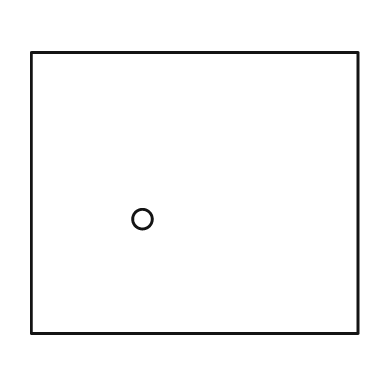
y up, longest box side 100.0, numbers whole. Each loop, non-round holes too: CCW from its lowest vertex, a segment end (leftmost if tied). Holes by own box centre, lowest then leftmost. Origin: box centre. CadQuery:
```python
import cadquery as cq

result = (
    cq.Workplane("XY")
    .moveTo(-50.0, -43.0)
    .lineTo(50.0, -43.0)
    .lineTo(50.0, 43.0)
    .lineTo(-50.0, 43.0)
    .close()
    .moveTo(-16.0, -8.0)
    .circle(3.0)
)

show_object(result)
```